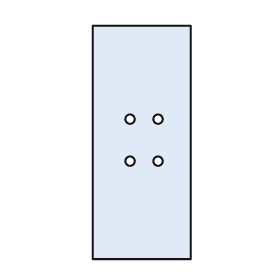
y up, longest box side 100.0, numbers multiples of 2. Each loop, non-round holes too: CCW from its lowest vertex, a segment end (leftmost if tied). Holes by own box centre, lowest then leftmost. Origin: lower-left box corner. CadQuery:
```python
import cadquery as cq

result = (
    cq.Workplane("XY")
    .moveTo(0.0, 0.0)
    .lineTo(42.0, 0.0)
    .lineTo(42.0, 100.0)
    .lineTo(0.0, 100.0)
    .close()
    .moveTo(16.0, 42.0)
    .circle(2.0)
    .moveTo(28.0, 42.0)
    .circle(2.0)
    .moveTo(16.0, 60.0)
    .circle(2.0)
    .moveTo(28.0, 60.0)
    .circle(2.0)
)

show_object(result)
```